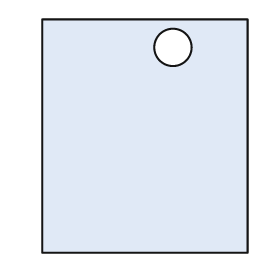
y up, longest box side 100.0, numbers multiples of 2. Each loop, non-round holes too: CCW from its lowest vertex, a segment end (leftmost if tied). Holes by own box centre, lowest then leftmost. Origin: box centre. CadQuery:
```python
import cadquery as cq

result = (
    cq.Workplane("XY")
    .moveTo(-44.0, -50.0)
    .lineTo(44.0, -50.0)
    .lineTo(44.0, 50.0)
    .lineTo(-44.0, 50.0)
    .close()
    .moveTo(12.0, 38.0)
    .circle(8.0)
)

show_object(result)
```